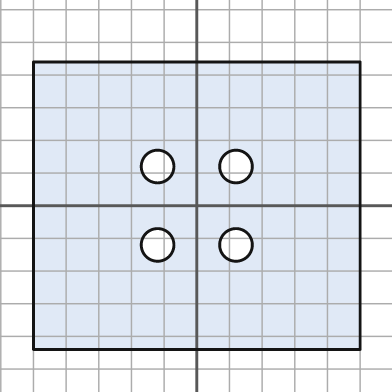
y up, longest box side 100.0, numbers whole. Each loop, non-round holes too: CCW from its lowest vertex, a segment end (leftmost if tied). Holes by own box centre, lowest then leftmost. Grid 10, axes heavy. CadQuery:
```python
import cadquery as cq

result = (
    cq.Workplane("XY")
    .moveTo(-50.0, -44.0)
    .lineTo(50.0, -44.0)
    .lineTo(50.0, 44.0)
    .lineTo(-50.0, 44.0)
    .close()
    .moveTo(-12.0, -12.0)
    .circle(5.0)
    .moveTo(12.0, -12.0)
    .circle(5.0)
    .moveTo(-12.0, 12.0)
    .circle(5.0)
    .moveTo(12.0, 12.0)
    .circle(5.0)
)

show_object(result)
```